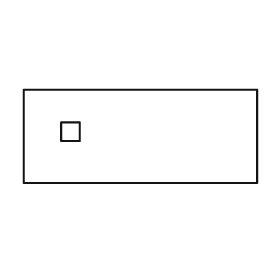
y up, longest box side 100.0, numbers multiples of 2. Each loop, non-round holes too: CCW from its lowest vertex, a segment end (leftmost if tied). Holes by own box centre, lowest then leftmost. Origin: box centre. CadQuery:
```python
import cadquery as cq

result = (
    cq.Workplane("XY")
    .moveTo(-50.0, -20.0)
    .lineTo(50.0, -20.0)
    .lineTo(50.0, 20.0)
    .lineTo(-50.0, 20.0)
    .close()
    .moveTo(-34.0, -2.0)
    .lineTo(-26.0, -2.0)
    .lineTo(-26.0, 6.0)
    .lineTo(-34.0, 6.0)
    .close()
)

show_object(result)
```